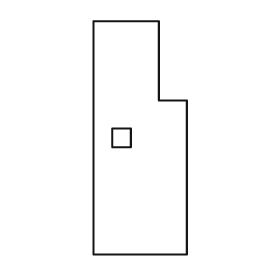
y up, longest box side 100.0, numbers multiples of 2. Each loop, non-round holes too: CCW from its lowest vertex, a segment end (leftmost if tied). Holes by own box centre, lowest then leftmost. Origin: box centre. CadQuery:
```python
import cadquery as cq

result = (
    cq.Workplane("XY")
    .moveTo(-20.0, -50.0)
    .lineTo(20.0, -50.0)
    .lineTo(20.0, 16.0)
    .lineTo(8.0, 16.0)
    .lineTo(8.0, 50.0)
    .lineTo(-20.0, 50.0)
    .close()
    .moveTo(-12.0, -4.0)
    .lineTo(-4.0, -4.0)
    .lineTo(-4.0, 4.0)
    .lineTo(-12.0, 4.0)
    .close()
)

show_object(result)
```